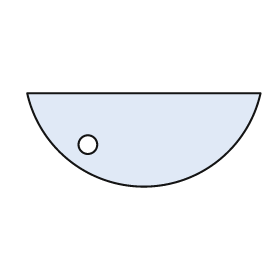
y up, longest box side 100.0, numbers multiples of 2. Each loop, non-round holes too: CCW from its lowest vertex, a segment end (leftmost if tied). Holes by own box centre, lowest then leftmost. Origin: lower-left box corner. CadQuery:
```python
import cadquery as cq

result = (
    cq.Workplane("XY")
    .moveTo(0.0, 40.0)
    .threePointArc((50.0, 0.0), (100.0, 40.0))
    .close()
    .moveTo(26.0, 18.0)
    .circle(4.0)
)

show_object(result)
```